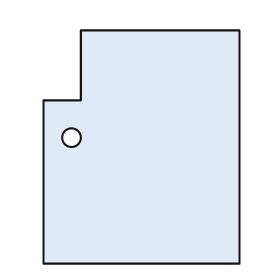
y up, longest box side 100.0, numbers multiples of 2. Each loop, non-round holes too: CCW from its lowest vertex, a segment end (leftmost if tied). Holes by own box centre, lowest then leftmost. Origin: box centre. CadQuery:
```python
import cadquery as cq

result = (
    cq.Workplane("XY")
    .moveTo(-42.0, -50.0)
    .lineTo(42.0, -50.0)
    .lineTo(42.0, 50.0)
    .lineTo(-26.0, 50.0)
    .lineTo(-26.0, 20.0)
    .lineTo(-42.0, 20.0)
    .close()
    .moveTo(-30.0, 4.0)
    .circle(4.0)
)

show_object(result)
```